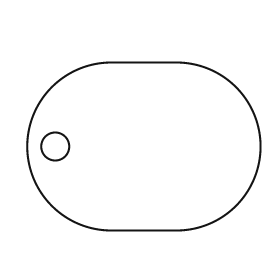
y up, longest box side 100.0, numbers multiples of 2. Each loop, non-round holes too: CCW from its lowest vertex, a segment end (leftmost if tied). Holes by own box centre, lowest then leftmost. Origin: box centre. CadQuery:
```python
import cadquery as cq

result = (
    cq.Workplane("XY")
    .moveTo(-14.0, -36.0)
    .lineTo(14.0, -36.0)
    .threePointArc((50.0, 0.0), (14.0, 36.0))
    .lineTo(-14.0, 36.0)
    .threePointArc((-50.0, 0.0), (-14.0, -36.0))
    .close()
    .moveTo(-38.0, 0.0)
    .circle(6.0)
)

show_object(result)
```